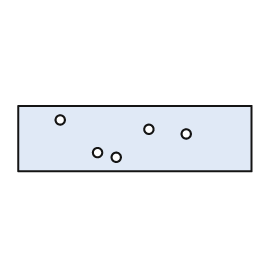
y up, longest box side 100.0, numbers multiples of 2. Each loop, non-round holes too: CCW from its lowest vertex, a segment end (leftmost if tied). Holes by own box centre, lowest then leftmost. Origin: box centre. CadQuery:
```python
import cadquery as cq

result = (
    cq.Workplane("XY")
    .moveTo(-50.0, -14.0)
    .lineTo(50.0, -14.0)
    .lineTo(50.0, 14.0)
    .lineTo(-50.0, 14.0)
    .close()
    .moveTo(-8.0, -8.0)
    .circle(2.0)
    .moveTo(-16.0, -6.0)
    .circle(2.0)
    .moveTo(22.0, 2.0)
    .circle(2.0)
    .moveTo(6.0, 4.0)
    .circle(2.0)
    .moveTo(-32.0, 8.0)
    .circle(2.0)
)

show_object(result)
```